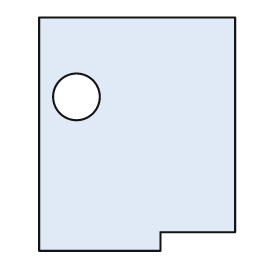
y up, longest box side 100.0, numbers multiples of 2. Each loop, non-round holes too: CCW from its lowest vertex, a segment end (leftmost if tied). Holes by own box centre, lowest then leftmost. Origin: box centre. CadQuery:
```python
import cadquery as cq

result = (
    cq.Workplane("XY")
    .moveTo(-42.0, -50.0)
    .lineTo(10.0, -50.0)
    .lineTo(10.0, -42.0)
    .lineTo(42.0, -42.0)
    .lineTo(42.0, 50.0)
    .lineTo(-42.0, 50.0)
    .close()
    .moveTo(-26.0, 16.0)
    .circle(10.0)
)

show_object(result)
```